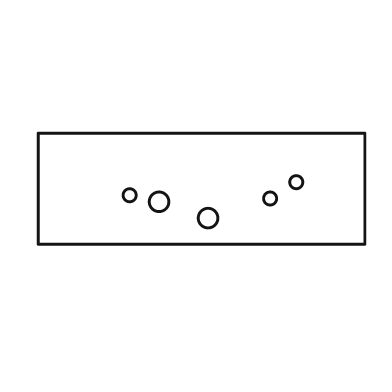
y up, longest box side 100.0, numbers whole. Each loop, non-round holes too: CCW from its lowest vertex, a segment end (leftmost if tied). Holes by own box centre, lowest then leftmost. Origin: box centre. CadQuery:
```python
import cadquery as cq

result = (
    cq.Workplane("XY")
    .moveTo(-50.0, -17.0)
    .lineTo(50.0, -17.0)
    .lineTo(50.0, 17.0)
    .lineTo(-50.0, 17.0)
    .close()
    .moveTo(2.0, -9.0)
    .circle(3.0)
    .moveTo(-13.0, -4.0)
    .circle(3.0)
    .moveTo(21.0, -3.0)
    .circle(2.0)
    .moveTo(-22.0, -2.0)
    .circle(2.0)
    .moveTo(29.0, 2.0)
    .circle(2.0)
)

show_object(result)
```